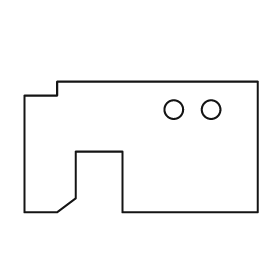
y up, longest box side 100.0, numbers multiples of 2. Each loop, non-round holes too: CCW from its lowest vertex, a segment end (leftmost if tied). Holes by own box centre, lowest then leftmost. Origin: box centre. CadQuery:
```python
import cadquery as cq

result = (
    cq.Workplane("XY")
    .moveTo(-50.0, -28.0)
    .lineTo(-36.0, -28.0)
    .lineTo(-28.0, -22.0)
    .lineTo(-28.0, -2.0)
    .lineTo(-8.0, -2.0)
    .lineTo(-8.0, -28.0)
    .lineTo(50.0, -28.0)
    .lineTo(50.0, 28.0)
    .lineTo(-36.0, 28.0)
    .lineTo(-36.0, 22.0)
    .lineTo(-50.0, 22.0)
    .close()
    .moveTo(14.0, 16.0)
    .circle(4.0)
    .moveTo(30.0, 16.0)
    .circle(4.0)
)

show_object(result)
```